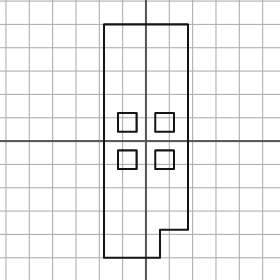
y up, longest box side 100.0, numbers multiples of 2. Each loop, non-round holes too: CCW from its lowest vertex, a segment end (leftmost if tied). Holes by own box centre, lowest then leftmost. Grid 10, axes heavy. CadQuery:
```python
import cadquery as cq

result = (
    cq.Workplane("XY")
    .moveTo(-18.0, -50.0)
    .lineTo(6.0, -50.0)
    .lineTo(6.0, -38.0)
    .lineTo(18.0, -38.0)
    .lineTo(18.0, 50.0)
    .lineTo(-18.0, 50.0)
    .close()
    .moveTo(-12.0, -12.0)
    .lineTo(-4.0, -12.0)
    .lineTo(-4.0, -4.0)
    .lineTo(-12.0, -4.0)
    .close()
    .moveTo(4.0, -12.0)
    .lineTo(12.0, -12.0)
    .lineTo(12.0, -4.0)
    .lineTo(4.0, -4.0)
    .close()
    .moveTo(-12.0, 4.0)
    .lineTo(-4.0, 4.0)
    .lineTo(-4.0, 12.0)
    .lineTo(-12.0, 12.0)
    .close()
    .moveTo(4.0, 4.0)
    .lineTo(12.0, 4.0)
    .lineTo(12.0, 12.0)
    .lineTo(4.0, 12.0)
    .close()
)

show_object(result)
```